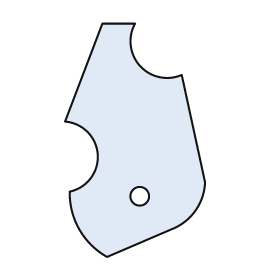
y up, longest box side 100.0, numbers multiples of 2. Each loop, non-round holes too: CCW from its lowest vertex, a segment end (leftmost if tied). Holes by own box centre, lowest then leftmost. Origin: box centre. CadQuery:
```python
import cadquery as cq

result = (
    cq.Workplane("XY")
    .moveTo(-12.0, -50.0)
    .lineTo(16.0, -38.0)
    .threePointArc((26.0, -30.0), (30.0, -18.0))
    .lineTo(20.0, 28.0)
    .threePointArc((2.0, 32.0), (0.0, 50.0))
    .lineTo(-14.0, 50.0)
    .lineTo(-30.0, 8.0)
    .threePointArc((-16.0, -6.0), (-28.0, -22.0))
    .threePointArc((-24.0, -38.0), (-12.0, -50.0))
    .close()
    .moveTo(2.0, -24.0)
    .circle(4.0)
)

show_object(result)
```